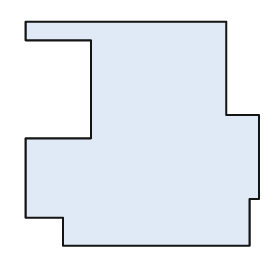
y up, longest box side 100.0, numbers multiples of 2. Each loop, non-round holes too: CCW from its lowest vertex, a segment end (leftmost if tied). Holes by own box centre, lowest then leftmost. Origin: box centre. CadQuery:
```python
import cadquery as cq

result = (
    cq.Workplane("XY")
    .moveTo(-34.0, -48.0)
    .lineTo(46.0, -48.0)
    .lineTo(46.0, -28.0)
    .lineTo(50.0, -28.0)
    .lineTo(50.0, 8.0)
    .lineTo(36.0, 8.0)
    .lineTo(36.0, 48.0)
    .lineTo(-50.0, 48.0)
    .lineTo(-50.0, 40.0)
    .lineTo(-22.0, 40.0)
    .lineTo(-22.0, -2.0)
    .lineTo(-50.0, -2.0)
    .lineTo(-50.0, -36.0)
    .lineTo(-34.0, -36.0)
    .close()
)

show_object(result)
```